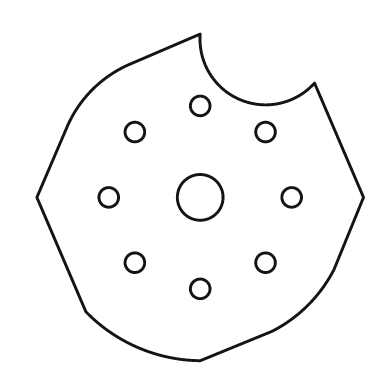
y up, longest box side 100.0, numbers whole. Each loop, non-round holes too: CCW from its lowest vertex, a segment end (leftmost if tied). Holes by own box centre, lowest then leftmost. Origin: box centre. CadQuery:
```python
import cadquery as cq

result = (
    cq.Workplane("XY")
    .moveTo(0.0, -50.0)
    .lineTo(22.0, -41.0)
    .threePointArc((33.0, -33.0), (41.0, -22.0))
    .lineTo(50.0, 0.0)
    .lineTo(35.0, 35.0)
    .threePointArc((12.0, 30.0), (0.0, 50.0))
    .lineTo(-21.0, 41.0)
    .threePointArc((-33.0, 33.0), (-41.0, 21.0))
    .lineTo(-50.0, 0.0)
    .lineTo(-35.0, -35.0)
    .threePointArc((-19.0, -46.0), (0.0, -50.0))
    .close()
    .moveTo(0.0, -28.0)
    .circle(3.0)
    .moveTo(-20.0, -20.0)
    .circle(3.0)
    .moveTo(20.0, -20.0)
    .circle(3.0)
    .moveTo(-28.0, 0.0)
    .circle(3.0)
    .moveTo(0.0, 0.0)
    .circle(7.0)
    .moveTo(28.0, 0.0)
    .circle(3.0)
    .moveTo(-20.0, 20.0)
    .circle(3.0)
    .moveTo(20.0, 20.0)
    .circle(3.0)
    .moveTo(0.0, 28.0)
    .circle(3.0)
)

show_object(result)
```